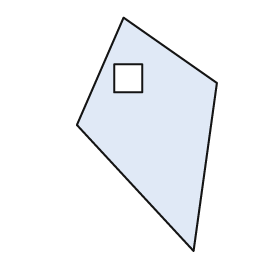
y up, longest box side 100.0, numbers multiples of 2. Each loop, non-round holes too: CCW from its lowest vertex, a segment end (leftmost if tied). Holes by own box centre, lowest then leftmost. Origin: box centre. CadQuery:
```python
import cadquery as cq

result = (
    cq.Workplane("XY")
    .moveTo(20.0, -50.0)
    .lineTo(30.0, 22.0)
    .lineTo(-10.0, 50.0)
    .lineTo(-30.0, 4.0)
    .close()
    .moveTo(-14.0, 18.0)
    .lineTo(-2.0, 18.0)
    .lineTo(-2.0, 30.0)
    .lineTo(-14.0, 30.0)
    .close()
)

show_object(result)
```